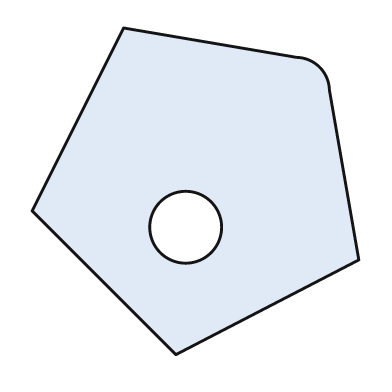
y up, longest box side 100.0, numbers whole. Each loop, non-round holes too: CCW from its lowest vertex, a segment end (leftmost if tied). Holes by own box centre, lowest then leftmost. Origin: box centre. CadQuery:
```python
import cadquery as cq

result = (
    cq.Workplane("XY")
    .moveTo(-6.0, -50.0)
    .lineTo(50.0, -21.0)
    .lineTo(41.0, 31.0)
    .threePointArc((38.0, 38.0), (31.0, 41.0))
    .lineTo(-22.0, 50.0)
    .lineTo(-50.0, -6.0)
    .close()
    .moveTo(-3.0, -11.0)
    .circle(11.0)
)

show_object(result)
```